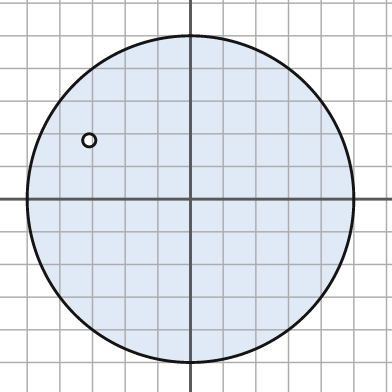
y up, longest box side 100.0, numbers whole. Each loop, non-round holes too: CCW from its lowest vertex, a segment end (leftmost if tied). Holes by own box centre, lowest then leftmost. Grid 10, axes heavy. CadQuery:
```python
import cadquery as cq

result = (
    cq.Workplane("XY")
    .moveTo(0.0, 0.0)
    .circle(50.0)
    .moveTo(-31.0, 18.0)
    .circle(2.0)
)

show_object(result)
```